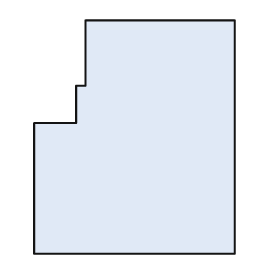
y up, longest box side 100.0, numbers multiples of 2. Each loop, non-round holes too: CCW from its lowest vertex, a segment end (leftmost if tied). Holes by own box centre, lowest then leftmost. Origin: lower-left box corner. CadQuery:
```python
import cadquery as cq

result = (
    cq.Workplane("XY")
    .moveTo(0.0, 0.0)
    .lineTo(86.0, 0.0)
    .lineTo(86.0, 100.0)
    .lineTo(22.0, 100.0)
    .lineTo(22.0, 72.0)
    .lineTo(18.0, 72.0)
    .lineTo(18.0, 56.0)
    .lineTo(0.0, 56.0)
    .close()
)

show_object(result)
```